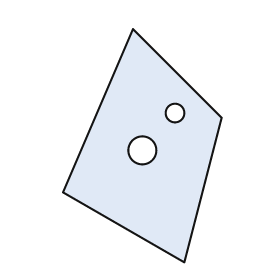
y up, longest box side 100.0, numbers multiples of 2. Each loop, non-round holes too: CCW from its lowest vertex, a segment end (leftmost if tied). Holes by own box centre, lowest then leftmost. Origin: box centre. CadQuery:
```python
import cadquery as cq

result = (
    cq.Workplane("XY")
    .moveTo(18.0, -50.0)
    .lineTo(34.0, 12.0)
    .lineTo(-4.0, 50.0)
    .lineTo(-34.0, -20.0)
    .close()
    .moveTo(0.0, -2.0)
    .circle(6.0)
    .moveTo(14.0, 14.0)
    .circle(4.0)
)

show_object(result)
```